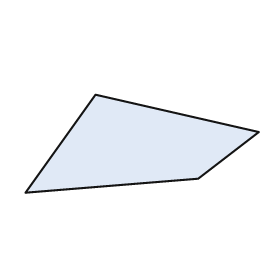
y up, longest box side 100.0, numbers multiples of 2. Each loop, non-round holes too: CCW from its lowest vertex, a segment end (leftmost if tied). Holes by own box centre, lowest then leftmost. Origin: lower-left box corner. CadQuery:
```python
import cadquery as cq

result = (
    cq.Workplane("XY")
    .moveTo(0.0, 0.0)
    .lineTo(74.0, 6.0)
    .lineTo(100.0, 26.0)
    .lineTo(30.0, 42.0)
    .close()
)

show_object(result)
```